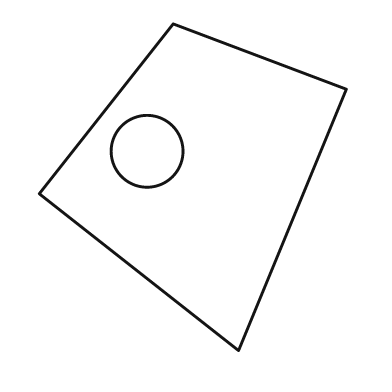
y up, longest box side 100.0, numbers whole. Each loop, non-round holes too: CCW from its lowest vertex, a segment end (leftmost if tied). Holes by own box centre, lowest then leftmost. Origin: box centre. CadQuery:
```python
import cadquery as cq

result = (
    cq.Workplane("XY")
    .moveTo(14.0, -50.0)
    .lineTo(47.0, 30.0)
    .lineTo(-6.0, 50.0)
    .lineTo(-47.0, -2.0)
    .close()
    .moveTo(-14.0, 11.0)
    .circle(11.0)
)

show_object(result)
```